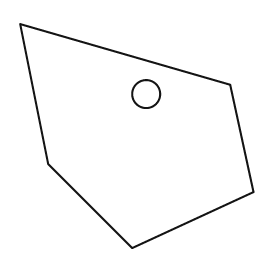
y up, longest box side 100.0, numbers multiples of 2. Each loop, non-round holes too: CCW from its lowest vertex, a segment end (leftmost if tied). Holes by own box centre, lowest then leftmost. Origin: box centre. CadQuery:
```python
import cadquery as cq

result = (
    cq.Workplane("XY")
    .moveTo(-2.0, -48.0)
    .lineTo(50.0, -24.0)
    .lineTo(40.0, 22.0)
    .lineTo(-50.0, 48.0)
    .lineTo(-38.0, -12.0)
    .close()
    .moveTo(4.0, 18.0)
    .circle(6.0)
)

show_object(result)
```